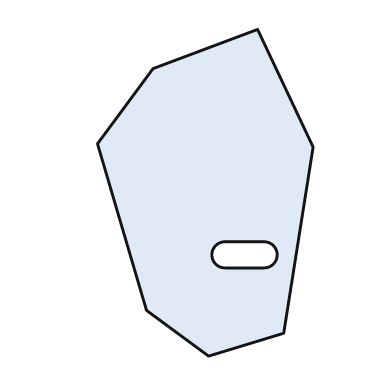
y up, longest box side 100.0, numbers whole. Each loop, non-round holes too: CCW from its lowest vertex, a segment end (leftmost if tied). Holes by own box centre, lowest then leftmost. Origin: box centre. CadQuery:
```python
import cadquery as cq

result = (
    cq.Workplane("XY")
    .moveTo(1.0, -50.0)
    .lineTo(24.0, -43.0)
    .lineTo(33.0, 14.0)
    .lineTo(16.0, 50.0)
    .lineTo(-16.0, 38.0)
    .lineTo(-33.0, 15.0)
    .lineTo(-18.0, -36.0)
    .close()
    .moveTo(6.0, -23.0)
    .lineTo(18.0, -23.0)
    .threePointArc((22.0, -19.0), (18.0, -15.0))
    .lineTo(6.0, -15.0)
    .threePointArc((2.0, -19.0), (6.0, -23.0))
    .close()
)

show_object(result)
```